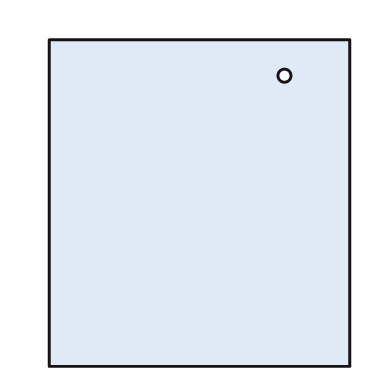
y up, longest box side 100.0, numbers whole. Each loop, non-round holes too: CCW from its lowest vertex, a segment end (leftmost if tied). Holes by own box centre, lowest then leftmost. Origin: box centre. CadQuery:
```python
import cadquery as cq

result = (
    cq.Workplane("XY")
    .moveTo(-46.0, -50.0)
    .lineTo(46.0, -50.0)
    .lineTo(46.0, 50.0)
    .lineTo(-46.0, 50.0)
    .close()
    .moveTo(26.0, 39.0)
    .circle(2.0)
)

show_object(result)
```